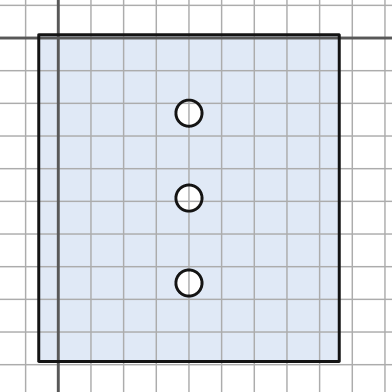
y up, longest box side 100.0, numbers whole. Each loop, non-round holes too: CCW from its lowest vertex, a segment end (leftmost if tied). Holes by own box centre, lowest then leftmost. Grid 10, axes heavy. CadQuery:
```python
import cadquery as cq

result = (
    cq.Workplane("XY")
    .moveTo(-6.0, -99.0)
    .lineTo(86.0, -99.0)
    .lineTo(86.0, 1.0)
    .lineTo(-6.0, 1.0)
    .close()
    .moveTo(40.0, -75.0)
    .circle(4.0)
    .moveTo(40.0, -49.0)
    .circle(4.0)
    .moveTo(40.0, -23.0)
    .circle(4.0)
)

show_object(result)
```